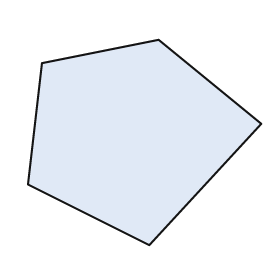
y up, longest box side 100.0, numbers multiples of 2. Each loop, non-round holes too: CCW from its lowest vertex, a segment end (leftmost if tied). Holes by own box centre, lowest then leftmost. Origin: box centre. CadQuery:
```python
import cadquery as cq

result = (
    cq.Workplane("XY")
    .moveTo(2.0, -44.0)
    .lineTo(50.0, 8.0)
    .lineTo(6.0, 44.0)
    .lineTo(-44.0, 34.0)
    .lineTo(-50.0, -18.0)
    .close()
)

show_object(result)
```